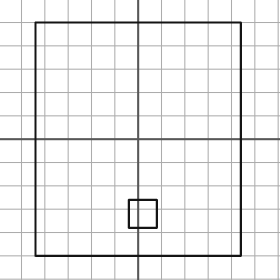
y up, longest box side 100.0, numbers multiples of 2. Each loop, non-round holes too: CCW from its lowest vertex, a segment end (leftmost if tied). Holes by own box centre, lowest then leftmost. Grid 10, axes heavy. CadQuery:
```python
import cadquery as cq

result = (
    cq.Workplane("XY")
    .moveTo(-44.0, -50.0)
    .lineTo(44.0, -50.0)
    .lineTo(44.0, 50.0)
    .lineTo(-44.0, 50.0)
    .close()
    .moveTo(-4.0, -38.0)
    .lineTo(8.0, -38.0)
    .lineTo(8.0, -26.0)
    .lineTo(-4.0, -26.0)
    .close()
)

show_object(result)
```